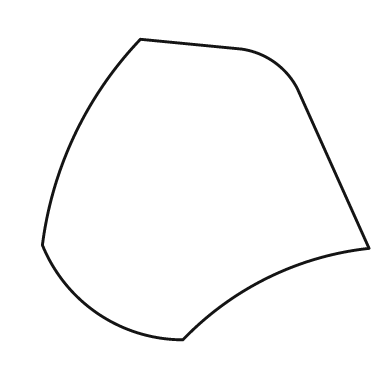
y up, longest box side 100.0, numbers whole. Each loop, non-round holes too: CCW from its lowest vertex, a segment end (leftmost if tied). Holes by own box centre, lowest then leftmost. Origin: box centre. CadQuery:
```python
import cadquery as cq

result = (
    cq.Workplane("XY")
    .moveTo(-7.0, -46.0)
    .threePointArc((19.0, -27.0), (50.0, -18.0))
    .lineTo(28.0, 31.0)
    .threePointArc((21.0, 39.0), (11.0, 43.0))
    .lineTo(-20.0, 46.0)
    .threePointArc((-40.0, 17.0), (-50.0, -17.0))
    .threePointArc((-33.0, -38.0), (-7.0, -46.0))
    .close()
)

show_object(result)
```